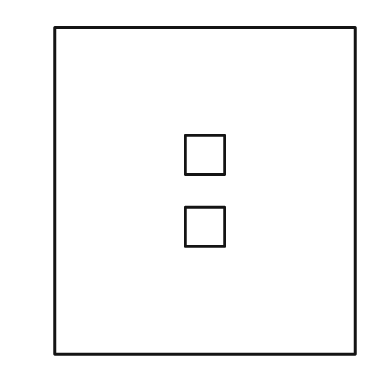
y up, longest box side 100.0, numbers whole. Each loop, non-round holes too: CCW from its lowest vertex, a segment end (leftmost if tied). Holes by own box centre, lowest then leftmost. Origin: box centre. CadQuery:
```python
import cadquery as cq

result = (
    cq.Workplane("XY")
    .moveTo(-46.0, -50.0)
    .lineTo(46.0, -50.0)
    .lineTo(46.0, 50.0)
    .lineTo(-46.0, 50.0)
    .close()
    .moveTo(-6.0, -17.0)
    .lineTo(6.0, -17.0)
    .lineTo(6.0, -5.0)
    .lineTo(-6.0, -5.0)
    .close()
    .moveTo(-6.0, 5.0)
    .lineTo(6.0, 5.0)
    .lineTo(6.0, 17.0)
    .lineTo(-6.0, 17.0)
    .close()
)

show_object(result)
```